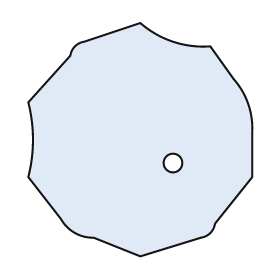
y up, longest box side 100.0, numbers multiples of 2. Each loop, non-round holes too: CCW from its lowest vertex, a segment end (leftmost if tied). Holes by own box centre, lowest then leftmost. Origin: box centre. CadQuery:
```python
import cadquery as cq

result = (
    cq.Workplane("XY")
    .moveTo(0.0, -50.0)
    .lineTo(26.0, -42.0)
    .threePointArc((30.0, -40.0), (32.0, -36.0))
    .lineTo(48.0, -16.0)
    .lineTo(48.0, 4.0)
    .threePointArc((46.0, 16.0), (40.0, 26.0))
    .lineTo(30.0, 40.0)
    .threePointArc((14.0, 42.0), (0.0, 50.0))
    .lineTo(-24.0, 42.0)
    .threePointArc((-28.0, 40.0), (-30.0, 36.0))
    .lineTo(-48.0, 16.0)
    .threePointArc((-46.0, 0.0), (-48.0, -16.0))
    .lineTo(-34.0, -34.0)
    .threePointArc((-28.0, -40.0), (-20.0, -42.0))
    .close()
    .moveTo(14.0, -10.0)
    .circle(4.0)
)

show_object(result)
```